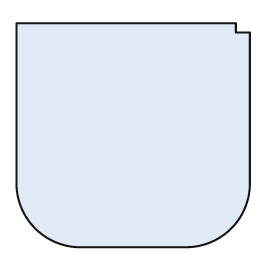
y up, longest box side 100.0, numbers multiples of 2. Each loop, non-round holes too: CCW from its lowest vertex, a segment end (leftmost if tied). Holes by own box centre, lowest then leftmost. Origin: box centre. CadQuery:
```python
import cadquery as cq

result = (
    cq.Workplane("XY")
    .moveTo(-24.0, -48.0)
    .lineTo(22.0, -48.0)
    .threePointArc((42.0, -40.0), (50.0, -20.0))
    .lineTo(50.0, 44.0)
    .lineTo(44.0, 44.0)
    .lineTo(44.0, 48.0)
    .lineTo(-50.0, 48.0)
    .lineTo(-50.0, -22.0)
    .threePointArc((-42.0, -40.0), (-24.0, -48.0))
    .close()
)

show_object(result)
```